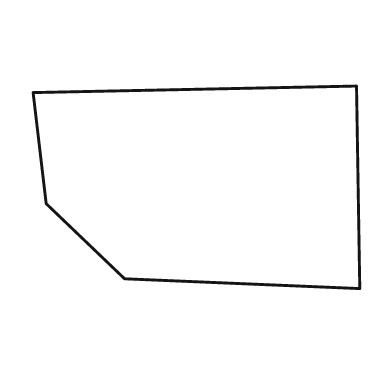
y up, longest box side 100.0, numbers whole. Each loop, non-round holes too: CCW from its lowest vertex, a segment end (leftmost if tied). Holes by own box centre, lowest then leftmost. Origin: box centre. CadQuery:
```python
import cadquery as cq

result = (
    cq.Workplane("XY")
    .moveTo(50.0, -31.0)
    .lineTo(49.0, 31.0)
    .lineTo(-50.0, 29.0)
    .lineTo(-46.0, -5.0)
    .lineTo(-22.0, -28.0)
    .close()
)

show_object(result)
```